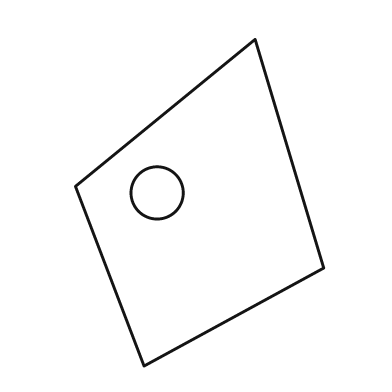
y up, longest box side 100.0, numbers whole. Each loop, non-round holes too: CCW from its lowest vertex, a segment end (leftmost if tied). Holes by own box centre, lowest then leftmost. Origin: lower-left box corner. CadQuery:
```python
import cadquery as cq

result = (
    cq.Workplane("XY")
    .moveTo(21.0, 0.0)
    .lineTo(76.0, 30.0)
    .lineTo(55.0, 100.0)
    .lineTo(0.0, 55.0)
    .close()
    .moveTo(25.0, 53.0)
    .circle(8.0)
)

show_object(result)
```